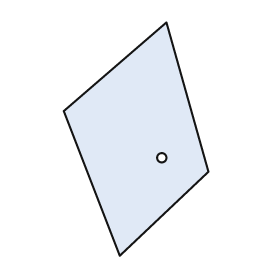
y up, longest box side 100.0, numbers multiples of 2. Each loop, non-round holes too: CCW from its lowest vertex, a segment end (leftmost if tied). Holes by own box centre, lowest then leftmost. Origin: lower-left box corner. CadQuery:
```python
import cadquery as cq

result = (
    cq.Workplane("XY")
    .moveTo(24.0, 0.0)
    .lineTo(62.0, 36.0)
    .lineTo(44.0, 100.0)
    .lineTo(0.0, 62.0)
    .close()
    .moveTo(42.0, 42.0)
    .circle(2.0)
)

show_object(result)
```